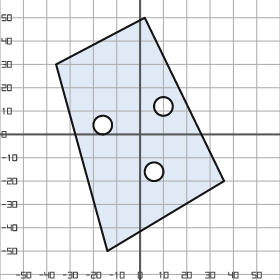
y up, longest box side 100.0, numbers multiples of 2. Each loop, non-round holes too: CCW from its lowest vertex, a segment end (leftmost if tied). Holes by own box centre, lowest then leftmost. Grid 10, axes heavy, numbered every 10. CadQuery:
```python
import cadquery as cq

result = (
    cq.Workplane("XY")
    .moveTo(-14.0, -50.0)
    .lineTo(36.0, -20.0)
    .lineTo(2.0, 50.0)
    .lineTo(-36.0, 30.0)
    .close()
    .moveTo(6.0, -16.0)
    .circle(4.0)
    .moveTo(-16.0, 4.0)
    .circle(4.0)
    .moveTo(10.0, 12.0)
    .circle(4.0)
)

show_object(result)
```